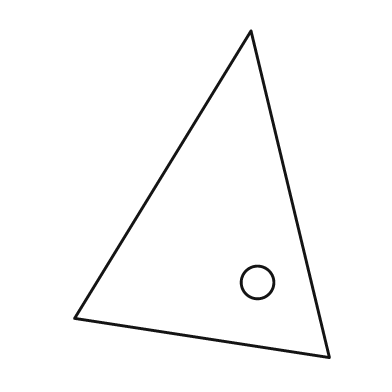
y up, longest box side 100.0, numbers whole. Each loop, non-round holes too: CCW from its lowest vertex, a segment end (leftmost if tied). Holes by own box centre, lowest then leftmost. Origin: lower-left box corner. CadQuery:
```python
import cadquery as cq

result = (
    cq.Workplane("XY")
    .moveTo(78.0, 0.0)
    .lineTo(54.0, 100.0)
    .lineTo(0.0, 12.0)
    .close()
    .moveTo(56.0, 23.0)
    .circle(5.0)
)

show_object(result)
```